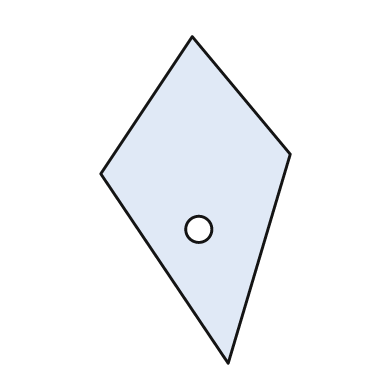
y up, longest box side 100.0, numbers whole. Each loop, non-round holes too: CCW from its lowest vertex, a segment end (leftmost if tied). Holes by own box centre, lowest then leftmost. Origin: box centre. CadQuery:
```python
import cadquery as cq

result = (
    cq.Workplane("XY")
    .moveTo(10.0, -50.0)
    .lineTo(29.0, 14.0)
    .lineTo(-1.0, 50.0)
    .lineTo(-29.0, 8.0)
    .close()
    .moveTo(1.0, -9.0)
    .circle(4.0)
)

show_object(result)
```